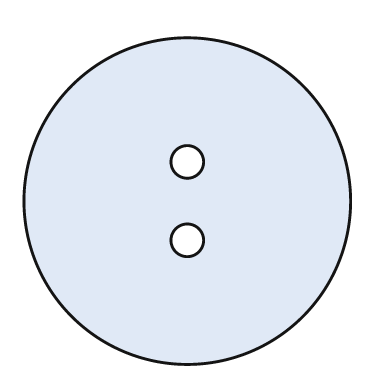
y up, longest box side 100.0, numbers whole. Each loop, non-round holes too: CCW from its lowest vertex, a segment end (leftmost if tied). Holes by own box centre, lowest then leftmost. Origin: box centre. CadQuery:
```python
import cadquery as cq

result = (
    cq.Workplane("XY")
    .moveTo(0.0, 0.0)
    .circle(50.0)
    .moveTo(0.0, -12.0)
    .circle(5.0)
    .moveTo(0.0, 12.0)
    .circle(5.0)
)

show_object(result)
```